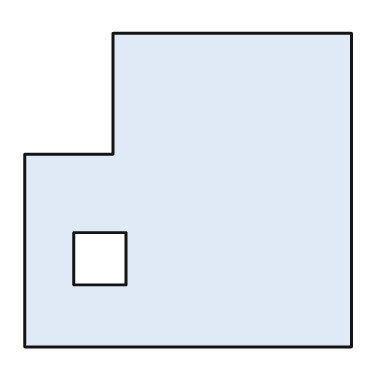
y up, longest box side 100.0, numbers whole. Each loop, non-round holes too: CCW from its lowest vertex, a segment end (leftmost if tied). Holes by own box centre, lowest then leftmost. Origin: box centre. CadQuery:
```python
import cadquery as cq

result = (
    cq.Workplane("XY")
    .moveTo(-50.0, -48.0)
    .lineTo(50.0, -48.0)
    .lineTo(50.0, 48.0)
    .lineTo(-23.0, 48.0)
    .lineTo(-23.0, 11.0)
    .lineTo(-50.0, 11.0)
    .close()
    .moveTo(-35.0, -29.0)
    .lineTo(-19.0, -29.0)
    .lineTo(-19.0, -13.0)
    .lineTo(-35.0, -13.0)
    .close()
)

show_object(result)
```